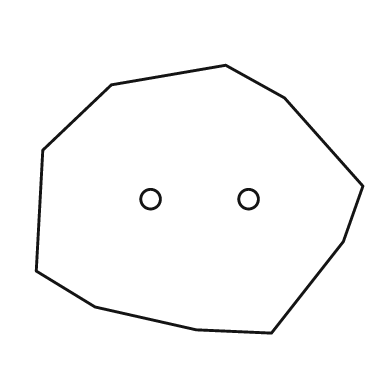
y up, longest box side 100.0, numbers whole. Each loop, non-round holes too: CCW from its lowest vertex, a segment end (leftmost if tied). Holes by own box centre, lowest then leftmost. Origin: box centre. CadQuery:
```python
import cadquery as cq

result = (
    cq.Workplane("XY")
    .moveTo(22.0, -41.0)
    .lineTo(44.0, -13.0)
    .lineTo(50.0, 4.0)
    .lineTo(26.0, 31.0)
    .lineTo(8.0, 41.0)
    .lineTo(-27.0, 35.0)
    .lineTo(-48.0, 15.0)
    .lineTo(-50.0, -22.0)
    .lineTo(-32.0, -33.0)
    .lineTo(-1.0, -40.0)
    .close()
    .moveTo(-15.0, 0.0)
    .circle(3.0)
    .moveTo(15.0, 0.0)
    .circle(3.0)
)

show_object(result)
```